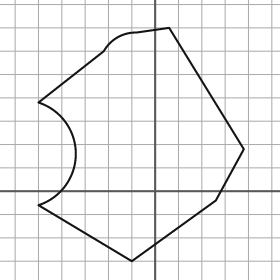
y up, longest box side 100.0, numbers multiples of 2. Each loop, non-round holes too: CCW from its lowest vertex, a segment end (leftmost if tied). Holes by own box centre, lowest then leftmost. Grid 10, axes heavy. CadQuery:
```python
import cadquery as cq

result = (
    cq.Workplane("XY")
    .moveTo(-10.0, -30.0)
    .lineTo(26.0, -4.0)
    .lineTo(38.0, 18.0)
    .lineTo(6.0, 70.0)
    .lineTo(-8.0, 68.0)
    .threePointArc((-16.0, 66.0), (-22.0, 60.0))
    .lineTo(-50.0, 38.0)
    .threePointArc((-34.0, 16.0), (-50.0, -6.0))
    .close()
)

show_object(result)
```